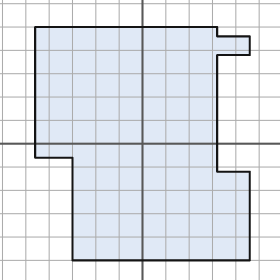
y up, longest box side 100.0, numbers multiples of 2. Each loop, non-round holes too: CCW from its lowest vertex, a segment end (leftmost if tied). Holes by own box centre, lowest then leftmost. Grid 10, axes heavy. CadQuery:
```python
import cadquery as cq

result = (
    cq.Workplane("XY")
    .moveTo(-30.0, -50.0)
    .lineTo(46.0, -50.0)
    .lineTo(46.0, -12.0)
    .lineTo(32.0, -12.0)
    .lineTo(32.0, 38.0)
    .lineTo(46.0, 38.0)
    .lineTo(46.0, 46.0)
    .lineTo(32.0, 46.0)
    .lineTo(32.0, 50.0)
    .lineTo(-46.0, 50.0)
    .lineTo(-46.0, -6.0)
    .lineTo(-30.0, -6.0)
    .close()
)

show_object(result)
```